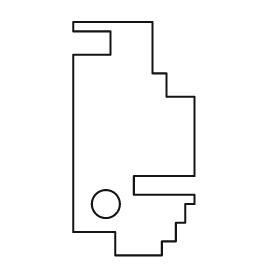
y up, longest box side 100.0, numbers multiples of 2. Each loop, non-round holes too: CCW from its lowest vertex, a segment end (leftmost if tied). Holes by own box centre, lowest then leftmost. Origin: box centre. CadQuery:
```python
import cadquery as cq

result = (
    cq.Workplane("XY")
    .moveTo(-8.0, -50.0)
    .lineTo(12.0, -50.0)
    .lineTo(12.0, -44.0)
    .lineTo(18.0, -44.0)
    .lineTo(18.0, -36.0)
    .lineTo(22.0, -36.0)
    .lineTo(22.0, -28.0)
    .lineTo(26.0, -28.0)
    .lineTo(26.0, -24.0)
    .lineTo(0.0, -24.0)
    .lineTo(0.0, -16.0)
    .lineTo(26.0, -16.0)
    .lineTo(26.0, 18.0)
    .lineTo(14.0, 18.0)
    .lineTo(14.0, 28.0)
    .lineTo(8.0, 28.0)
    .lineTo(8.0, 50.0)
    .lineTo(-26.0, 50.0)
    .lineTo(-26.0, 46.0)
    .lineTo(-10.0, 46.0)
    .lineTo(-10.0, 36.0)
    .lineTo(-26.0, 36.0)
    .lineTo(-26.0, -40.0)
    .lineTo(-8.0, -40.0)
    .close()
    .moveTo(-12.0, -28.0)
    .circle(6.0)
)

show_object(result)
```